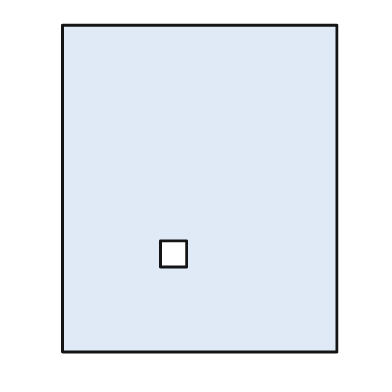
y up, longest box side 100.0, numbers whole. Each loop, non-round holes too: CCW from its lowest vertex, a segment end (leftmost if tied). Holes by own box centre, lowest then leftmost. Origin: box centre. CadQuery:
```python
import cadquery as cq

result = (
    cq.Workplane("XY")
    .moveTo(-42.0, -50.0)
    .lineTo(42.0, -50.0)
    .lineTo(42.0, 50.0)
    .lineTo(-42.0, 50.0)
    .close()
    .moveTo(-12.0, -24.0)
    .lineTo(-4.0, -24.0)
    .lineTo(-4.0, -16.0)
    .lineTo(-12.0, -16.0)
    .close()
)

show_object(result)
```